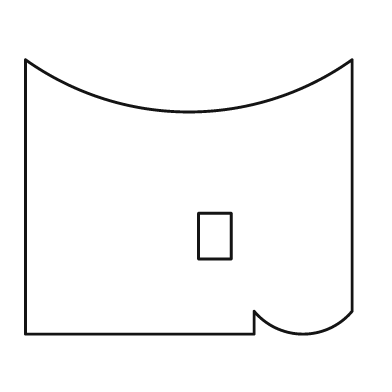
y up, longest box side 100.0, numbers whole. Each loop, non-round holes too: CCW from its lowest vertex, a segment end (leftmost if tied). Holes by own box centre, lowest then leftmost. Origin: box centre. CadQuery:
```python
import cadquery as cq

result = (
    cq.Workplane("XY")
    .moveTo(-50.0, -42.0)
    .lineTo(20.0, -42.0)
    .lineTo(20.0, -35.0)
    .threePointArc((35.0, -42.0), (50.0, -35.0))
    .lineTo(50.0, 42.0)
    .threePointArc((0.0, 26.0), (-50.0, 42.0))
    .close()
    .moveTo(3.0, -19.0)
    .lineTo(13.0, -19.0)
    .lineTo(13.0, -5.0)
    .lineTo(3.0, -5.0)
    .close()
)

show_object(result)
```